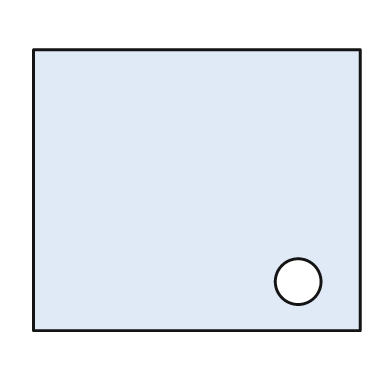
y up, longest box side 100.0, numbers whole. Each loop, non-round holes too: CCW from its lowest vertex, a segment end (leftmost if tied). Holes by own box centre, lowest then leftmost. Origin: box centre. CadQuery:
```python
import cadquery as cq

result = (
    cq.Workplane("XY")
    .moveTo(-50.0, -43.0)
    .lineTo(50.0, -43.0)
    .lineTo(50.0, 43.0)
    .lineTo(-50.0, 43.0)
    .close()
    .moveTo(31.0, -28.0)
    .circle(7.0)
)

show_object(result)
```